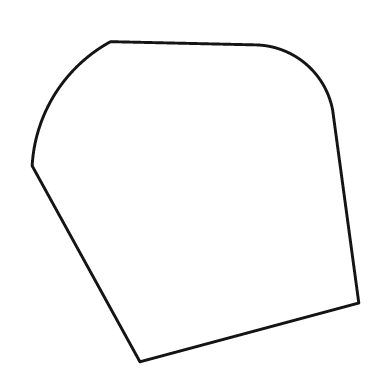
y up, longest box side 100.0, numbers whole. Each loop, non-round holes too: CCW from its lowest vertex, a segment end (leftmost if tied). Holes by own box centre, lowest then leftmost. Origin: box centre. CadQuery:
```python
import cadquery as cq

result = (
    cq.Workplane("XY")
    .moveTo(-17.0, -49.0)
    .lineTo(50.0, -31.0)
    .lineTo(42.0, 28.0)
    .threePointArc((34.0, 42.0), (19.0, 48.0))
    .lineTo(-26.0, 49.0)
    .threePointArc((-43.0, 33.0), (-50.0, 11.0))
    .close()
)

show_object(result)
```